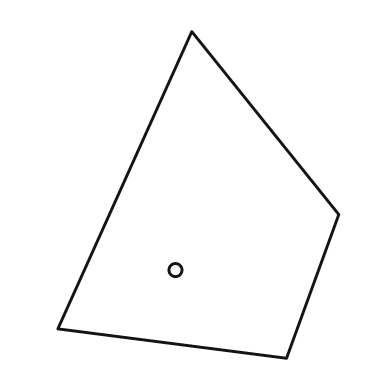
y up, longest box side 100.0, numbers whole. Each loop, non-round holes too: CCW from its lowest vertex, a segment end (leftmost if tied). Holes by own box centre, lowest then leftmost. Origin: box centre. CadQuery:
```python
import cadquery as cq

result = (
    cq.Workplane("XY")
    .moveTo(27.0, -50.0)
    .lineTo(43.0, -6.0)
    .lineTo(-2.0, 50.0)
    .lineTo(-43.0, -41.0)
    .close()
    .moveTo(-7.0, -23.0)
    .circle(2.0)
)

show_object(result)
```